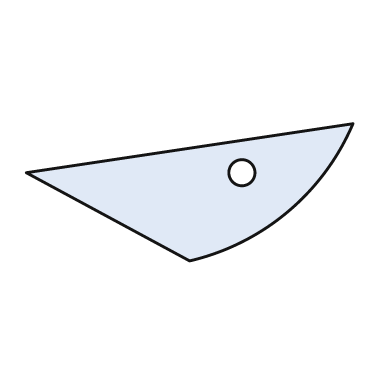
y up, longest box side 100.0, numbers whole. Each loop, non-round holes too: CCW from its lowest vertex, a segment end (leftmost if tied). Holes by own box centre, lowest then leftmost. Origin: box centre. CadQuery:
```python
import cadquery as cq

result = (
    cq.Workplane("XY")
    .moveTo(0.0, -21.0)
    .threePointArc((30.0, -6.0), (50.0, 21.0))
    .lineTo(-50.0, 6.0)
    .close()
    .moveTo(16.0, 6.0)
    .circle(4.0)
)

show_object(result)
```